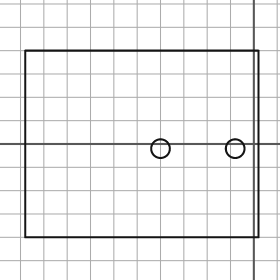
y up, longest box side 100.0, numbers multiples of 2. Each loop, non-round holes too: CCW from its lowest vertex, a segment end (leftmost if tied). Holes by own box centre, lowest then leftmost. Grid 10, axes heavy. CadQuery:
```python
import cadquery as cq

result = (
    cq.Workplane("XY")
    .moveTo(-98.0, -40.0)
    .lineTo(2.0, -40.0)
    .lineTo(2.0, 40.0)
    .lineTo(-98.0, 40.0)
    .close()
    .moveTo(-40.0, -2.0)
    .circle(4.0)
    .moveTo(-8.0, -2.0)
    .circle(4.0)
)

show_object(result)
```